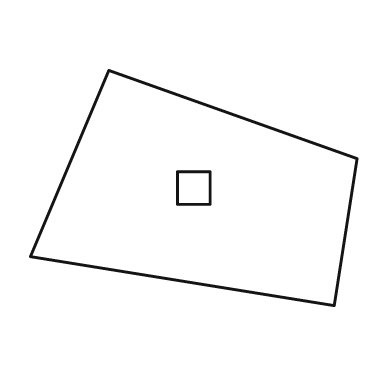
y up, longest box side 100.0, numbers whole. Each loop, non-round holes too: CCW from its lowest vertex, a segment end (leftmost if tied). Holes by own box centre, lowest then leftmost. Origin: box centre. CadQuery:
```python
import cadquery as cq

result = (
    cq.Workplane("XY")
    .moveTo(43.0, -36.0)
    .lineTo(50.0, 9.0)
    .lineTo(-26.0, 36.0)
    .lineTo(-50.0, -21.0)
    .close()
    .moveTo(-5.0, -5.0)
    .lineTo(5.0, -5.0)
    .lineTo(5.0, 5.0)
    .lineTo(-5.0, 5.0)
    .close()
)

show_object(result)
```